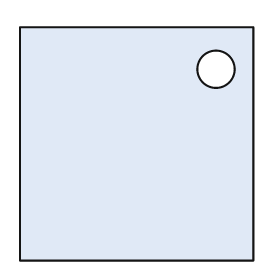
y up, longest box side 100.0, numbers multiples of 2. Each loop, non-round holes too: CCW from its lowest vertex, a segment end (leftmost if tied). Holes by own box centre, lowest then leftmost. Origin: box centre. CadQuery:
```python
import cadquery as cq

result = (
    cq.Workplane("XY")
    .moveTo(-50.0, -50.0)
    .lineTo(50.0, -50.0)
    .lineTo(50.0, 50.0)
    .lineTo(-50.0, 50.0)
    .close()
    .moveTo(34.0, 32.0)
    .circle(8.0)
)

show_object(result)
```